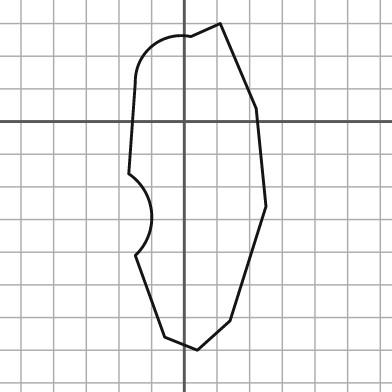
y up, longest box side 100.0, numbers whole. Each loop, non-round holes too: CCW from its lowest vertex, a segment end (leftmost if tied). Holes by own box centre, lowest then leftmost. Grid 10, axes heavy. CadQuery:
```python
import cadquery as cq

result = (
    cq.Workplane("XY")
    .moveTo(4.0, -70.0)
    .lineTo(14.0, -61.0)
    .lineTo(25.0, -26.0)
    .lineTo(22.0, 4.0)
    .lineTo(11.0, 30.0)
    .lineTo(2.0, 26.0)
    .threePointArc((-10.0, 23.0), (-15.0, 12.0))
    .lineTo(-17.0, -16.0)
    .threePointArc((-10.0, -28.0), (-15.0, -41.0))
    .lineTo(-6.0, -66.0)
    .close()
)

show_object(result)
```